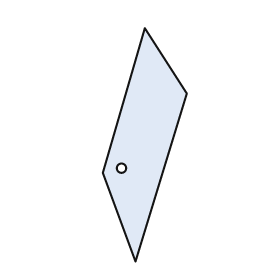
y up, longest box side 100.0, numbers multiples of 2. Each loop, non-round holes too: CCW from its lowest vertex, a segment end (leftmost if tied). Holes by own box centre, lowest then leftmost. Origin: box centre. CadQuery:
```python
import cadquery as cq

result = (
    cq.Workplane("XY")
    .moveTo(-4.0, -50.0)
    .lineTo(18.0, 22.0)
    .lineTo(0.0, 50.0)
    .lineTo(-18.0, -12.0)
    .close()
    .moveTo(-10.0, -10.0)
    .circle(2.0)
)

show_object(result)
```